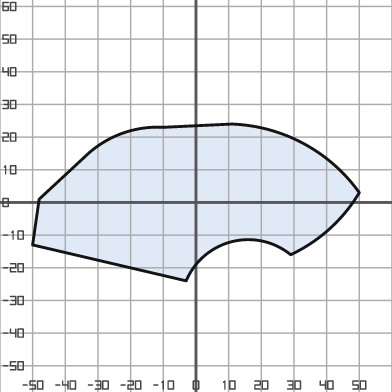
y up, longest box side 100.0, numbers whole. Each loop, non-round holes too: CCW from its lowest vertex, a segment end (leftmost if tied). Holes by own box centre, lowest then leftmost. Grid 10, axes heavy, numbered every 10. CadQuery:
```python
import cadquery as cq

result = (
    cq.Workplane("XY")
    .moveTo(-3.0, -24.0)
    .threePointArc((11.0, -12.0), (29.0, -16.0))
    .threePointArc((41.0, -8.0), (50.0, 3.0))
    .threePointArc((33.0, 18.0), (11.0, 24.0))
    .lineTo(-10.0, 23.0)
    .threePointArc((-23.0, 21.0), (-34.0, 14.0))
    .lineTo(-48.0, 1.0)
    .lineTo(-50.0, -13.0)
    .close()
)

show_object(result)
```